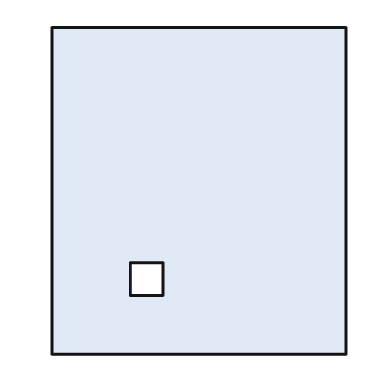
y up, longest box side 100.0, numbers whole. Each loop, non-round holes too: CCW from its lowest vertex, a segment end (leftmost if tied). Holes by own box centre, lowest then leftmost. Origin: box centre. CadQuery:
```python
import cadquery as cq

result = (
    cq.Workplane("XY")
    .moveTo(-45.0, -50.0)
    .lineTo(45.0, -50.0)
    .lineTo(45.0, 50.0)
    .lineTo(-45.0, 50.0)
    .close()
    .moveTo(-21.0, -32.0)
    .lineTo(-11.0, -32.0)
    .lineTo(-11.0, -22.0)
    .lineTo(-21.0, -22.0)
    .close()
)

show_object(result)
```